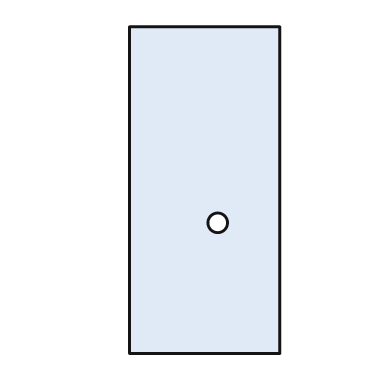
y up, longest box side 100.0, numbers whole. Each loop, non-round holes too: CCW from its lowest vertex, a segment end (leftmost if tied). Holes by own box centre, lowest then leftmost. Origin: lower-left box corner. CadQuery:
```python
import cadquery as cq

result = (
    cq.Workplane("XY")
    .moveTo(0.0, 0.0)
    .lineTo(46.0, 0.0)
    .lineTo(46.0, 100.0)
    .lineTo(0.0, 100.0)
    .close()
    .moveTo(27.0, 40.0)
    .circle(3.0)
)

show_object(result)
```